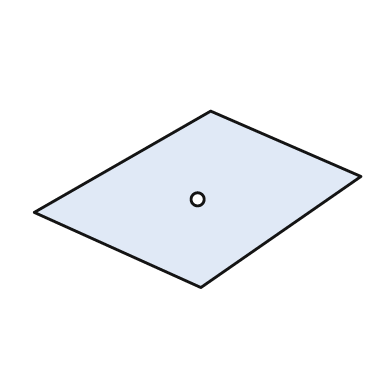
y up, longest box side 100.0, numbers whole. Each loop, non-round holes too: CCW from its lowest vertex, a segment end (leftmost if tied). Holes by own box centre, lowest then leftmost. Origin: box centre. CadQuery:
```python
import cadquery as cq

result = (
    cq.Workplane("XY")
    .moveTo(1.0, -27.0)
    .lineTo(50.0, 7.0)
    .lineTo(4.0, 27.0)
    .lineTo(-50.0, -4.0)
    .close()
    .moveTo(0.0, 0.0)
    .circle(2.0)
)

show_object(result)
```